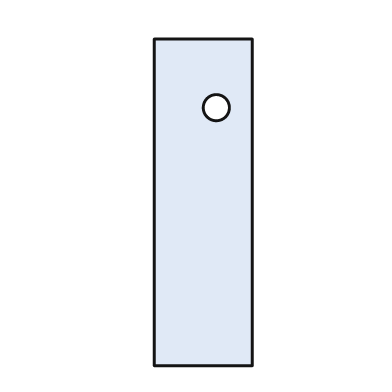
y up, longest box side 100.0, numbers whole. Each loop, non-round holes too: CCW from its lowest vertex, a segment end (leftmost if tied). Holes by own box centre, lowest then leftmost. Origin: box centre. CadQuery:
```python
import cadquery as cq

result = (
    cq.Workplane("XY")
    .moveTo(-15.0, -50.0)
    .lineTo(15.0, -50.0)
    .lineTo(15.0, 50.0)
    .lineTo(-15.0, 50.0)
    .close()
    .moveTo(4.0, 29.0)
    .circle(4.0)
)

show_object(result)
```